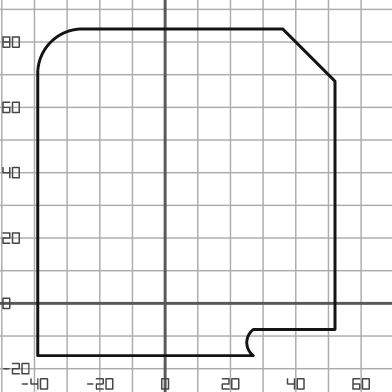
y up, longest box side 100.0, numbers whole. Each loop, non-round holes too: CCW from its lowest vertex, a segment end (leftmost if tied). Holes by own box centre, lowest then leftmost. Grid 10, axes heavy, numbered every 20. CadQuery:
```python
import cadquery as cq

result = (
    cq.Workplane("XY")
    .moveTo(-39.0, -16.0)
    .lineTo(27.0, -16.0)
    .threePointArc((25.0, -12.0), (27.0, -8.0))
    .lineTo(52.0, -8.0)
    .lineTo(52.0, 68.0)
    .lineTo(36.0, 84.0)
    .lineTo(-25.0, 84.0)
    .threePointArc((-35.0, 80.0), (-39.0, 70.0))
    .close()
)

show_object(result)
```